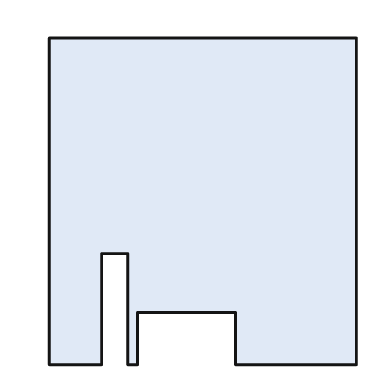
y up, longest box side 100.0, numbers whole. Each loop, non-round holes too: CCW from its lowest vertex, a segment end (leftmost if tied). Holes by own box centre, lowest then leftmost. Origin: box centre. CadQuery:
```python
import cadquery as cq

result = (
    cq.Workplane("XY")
    .moveTo(-47.0, -50.0)
    .lineTo(-31.0, -50.0)
    .lineTo(-31.0, -16.0)
    .lineTo(-23.0, -16.0)
    .lineTo(-23.0, -50.0)
    .lineTo(-20.0, -50.0)
    .lineTo(-20.0, -34.0)
    .lineTo(10.0, -34.0)
    .lineTo(10.0, -50.0)
    .lineTo(47.0, -50.0)
    .lineTo(47.0, 50.0)
    .lineTo(-47.0, 50.0)
    .close()
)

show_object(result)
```